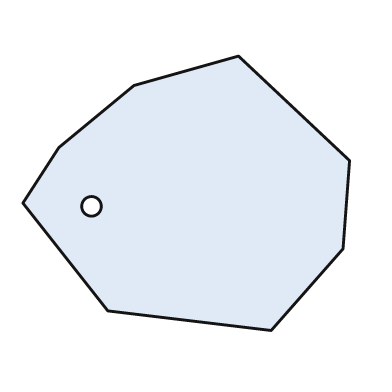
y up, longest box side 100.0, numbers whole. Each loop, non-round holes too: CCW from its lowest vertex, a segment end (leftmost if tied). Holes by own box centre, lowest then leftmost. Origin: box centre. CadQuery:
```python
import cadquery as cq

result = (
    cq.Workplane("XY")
    .moveTo(26.0, -42.0)
    .lineTo(48.0, -17.0)
    .lineTo(50.0, 10.0)
    .lineTo(16.0, 42.0)
    .lineTo(-16.0, 33.0)
    .lineTo(-39.0, 14.0)
    .lineTo(-50.0, -3.0)
    .lineTo(-24.0, -36.0)
    .close()
    .moveTo(-29.0, -4.0)
    .circle(3.0)
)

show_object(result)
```